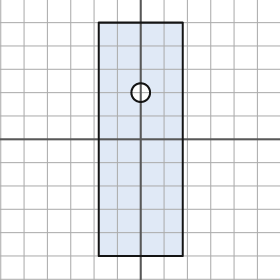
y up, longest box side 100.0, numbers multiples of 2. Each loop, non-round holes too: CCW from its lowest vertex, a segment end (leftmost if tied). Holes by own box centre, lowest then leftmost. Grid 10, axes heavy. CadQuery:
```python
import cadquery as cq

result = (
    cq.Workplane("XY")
    .moveTo(-18.0, -50.0)
    .lineTo(18.0, -50.0)
    .lineTo(18.0, 50.0)
    .lineTo(-18.0, 50.0)
    .close()
    .moveTo(0.0, 20.0)
    .circle(4.0)
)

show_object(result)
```